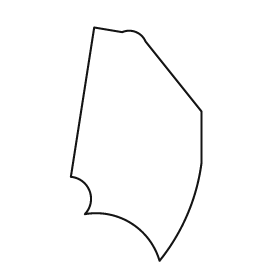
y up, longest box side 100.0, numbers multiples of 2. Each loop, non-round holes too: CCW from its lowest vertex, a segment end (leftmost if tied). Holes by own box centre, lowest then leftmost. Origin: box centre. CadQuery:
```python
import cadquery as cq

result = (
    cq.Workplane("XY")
    .moveTo(10.0, -50.0)
    .threePointArc((22.0, -30.0), (28.0, -8.0))
    .lineTo(28.0, 14.0)
    .lineTo(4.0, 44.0)
    .threePointArc((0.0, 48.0), (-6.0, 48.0))
    .lineTo(-18.0, 50.0)
    .lineTo(-28.0, -14.0)
    .threePointArc((-20.0, -20.0), (-22.0, -30.0))
    .threePointArc((-2.0, -34.0), (10.0, -50.0))
    .close()
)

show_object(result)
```